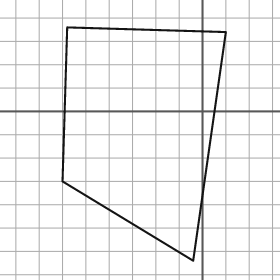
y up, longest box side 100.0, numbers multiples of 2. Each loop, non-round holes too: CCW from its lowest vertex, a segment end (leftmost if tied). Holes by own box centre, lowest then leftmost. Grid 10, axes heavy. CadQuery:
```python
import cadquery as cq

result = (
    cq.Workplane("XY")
    .moveTo(-4.0, -64.0)
    .lineTo(10.0, 34.0)
    .lineTo(-58.0, 36.0)
    .lineTo(-60.0, -30.0)
    .close()
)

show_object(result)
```